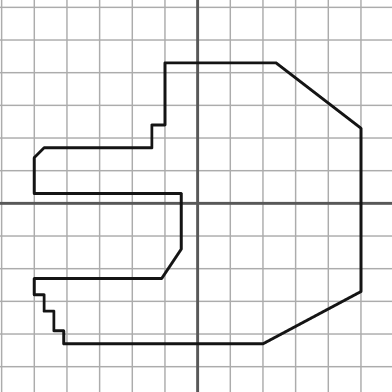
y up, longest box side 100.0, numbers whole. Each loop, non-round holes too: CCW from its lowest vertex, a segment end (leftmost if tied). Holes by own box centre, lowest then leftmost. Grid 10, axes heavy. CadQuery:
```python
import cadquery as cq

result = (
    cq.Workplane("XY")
    .moveTo(-41.0, -43.0)
    .lineTo(20.0, -43.0)
    .lineTo(50.0, -27.0)
    .lineTo(50.0, 23.0)
    .lineTo(24.0, 43.0)
    .lineTo(-10.0, 43.0)
    .lineTo(-10.0, 24.0)
    .lineTo(-14.0, 24.0)
    .lineTo(-14.0, 17.0)
    .lineTo(-47.0, 17.0)
    .lineTo(-50.0, 14.0)
    .lineTo(-50.0, 3.0)
    .lineTo(-5.0, 3.0)
    .lineTo(-5.0, -14.0)
    .lineTo(-11.0, -23.0)
    .lineTo(-50.0, -23.0)
    .lineTo(-50.0, -28.0)
    .lineTo(-47.0, -28.0)
    .lineTo(-47.0, -33.0)
    .lineTo(-44.0, -33.0)
    .lineTo(-44.0, -39.0)
    .lineTo(-41.0, -39.0)
    .close()
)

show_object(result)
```